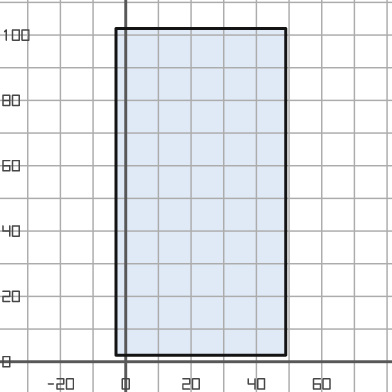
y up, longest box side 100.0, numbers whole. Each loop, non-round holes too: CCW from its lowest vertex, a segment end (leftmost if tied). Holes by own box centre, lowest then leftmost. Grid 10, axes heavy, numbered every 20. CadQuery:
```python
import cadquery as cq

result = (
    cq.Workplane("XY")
    .moveTo(-3.0, 2.0)
    .lineTo(49.0, 2.0)
    .lineTo(49.0, 102.0)
    .lineTo(-3.0, 102.0)
    .close()
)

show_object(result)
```